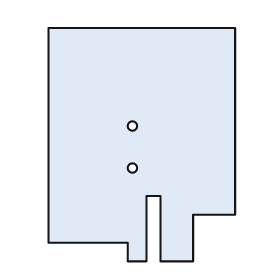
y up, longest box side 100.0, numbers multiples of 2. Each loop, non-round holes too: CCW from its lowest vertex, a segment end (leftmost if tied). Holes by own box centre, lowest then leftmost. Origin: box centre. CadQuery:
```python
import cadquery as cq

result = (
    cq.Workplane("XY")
    .moveTo(-6.0, -50.0)
    .lineTo(2.0, -50.0)
    .lineTo(2.0, -22.0)
    .lineTo(8.0, -22.0)
    .lineTo(8.0, -50.0)
    .lineTo(22.0, -50.0)
    .lineTo(22.0, -30.0)
    .lineTo(40.0, -30.0)
    .lineTo(40.0, 50.0)
    .lineTo(-40.0, 50.0)
    .lineTo(-40.0, -42.0)
    .lineTo(-6.0, -42.0)
    .close()
    .moveTo(-4.0, -10.0)
    .circle(2.0)
    .moveTo(-4.0, 8.0)
    .circle(2.0)
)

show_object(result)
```